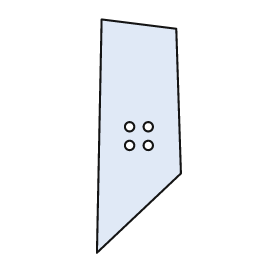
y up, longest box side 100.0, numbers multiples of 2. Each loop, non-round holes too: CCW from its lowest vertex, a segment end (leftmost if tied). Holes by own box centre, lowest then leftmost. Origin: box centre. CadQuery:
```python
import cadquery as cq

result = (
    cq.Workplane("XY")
    .moveTo(-18.0, -50.0)
    .lineTo(18.0, -16.0)
    .lineTo(16.0, 46.0)
    .lineTo(-16.0, 50.0)
    .close()
    .moveTo(-4.0, -4.0)
    .circle(2.0)
    .moveTo(4.0, -4.0)
    .circle(2.0)
    .moveTo(-4.0, 4.0)
    .circle(2.0)
    .moveTo(4.0, 4.0)
    .circle(2.0)
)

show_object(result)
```